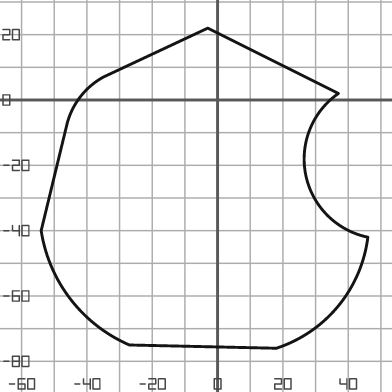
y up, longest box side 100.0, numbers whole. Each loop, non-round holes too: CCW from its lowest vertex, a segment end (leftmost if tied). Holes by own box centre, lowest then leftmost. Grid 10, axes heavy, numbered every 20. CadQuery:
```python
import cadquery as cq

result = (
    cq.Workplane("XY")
    .moveTo(18.0, -76.0)
    .threePointArc((37.0, -63.0), (46.0, -42.0))
    .threePointArc((27.0, -23.0), (37.0, 2.0))
    .lineTo(-3.0, 22.0)
    .lineTo(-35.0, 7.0)
    .threePointArc((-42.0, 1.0), (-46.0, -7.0))
    .lineTo(-54.0, -40.0)
    .threePointArc((-45.0, -61.0), (-27.0, -75.0))
    .close()
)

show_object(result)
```